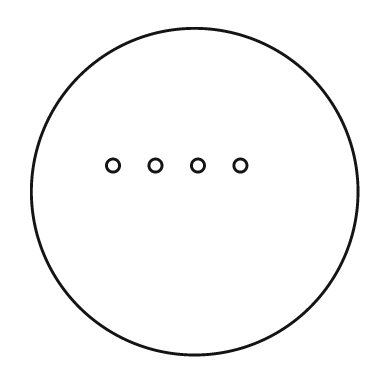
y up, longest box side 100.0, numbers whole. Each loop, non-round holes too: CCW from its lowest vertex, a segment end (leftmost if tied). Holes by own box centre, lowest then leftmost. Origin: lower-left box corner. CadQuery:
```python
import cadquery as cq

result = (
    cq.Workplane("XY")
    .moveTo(50.0, 50.0)
    .circle(50.0)
    .moveTo(25.0, 58.0)
    .circle(2.0)
    .moveTo(38.0, 58.0)
    .circle(2.0)
    .moveTo(51.0, 58.0)
    .circle(2.0)
    .moveTo(64.0, 58.0)
    .circle(2.0)
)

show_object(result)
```